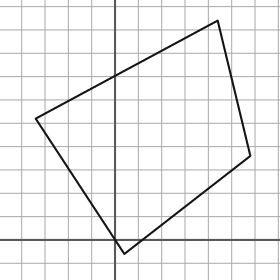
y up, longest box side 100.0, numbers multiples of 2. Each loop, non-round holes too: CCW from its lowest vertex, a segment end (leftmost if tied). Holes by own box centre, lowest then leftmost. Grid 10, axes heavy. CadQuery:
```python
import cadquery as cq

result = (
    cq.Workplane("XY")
    .moveTo(4.0, -6.0)
    .lineTo(58.0, 36.0)
    .lineTo(44.0, 94.0)
    .lineTo(-34.0, 52.0)
    .close()
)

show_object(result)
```